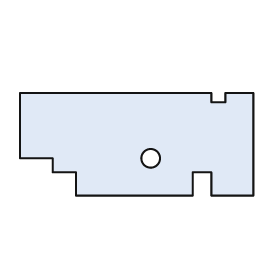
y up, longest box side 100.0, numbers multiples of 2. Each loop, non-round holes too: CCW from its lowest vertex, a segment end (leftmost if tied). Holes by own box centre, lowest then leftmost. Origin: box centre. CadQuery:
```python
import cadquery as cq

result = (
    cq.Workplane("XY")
    .moveTo(-26.0, -22.0)
    .lineTo(24.0, -22.0)
    .lineTo(24.0, -12.0)
    .lineTo(32.0, -12.0)
    .lineTo(32.0, -22.0)
    .lineTo(50.0, -22.0)
    .lineTo(50.0, 22.0)
    .lineTo(38.0, 22.0)
    .lineTo(38.0, 18.0)
    .lineTo(32.0, 18.0)
    .lineTo(32.0, 22.0)
    .lineTo(-50.0, 22.0)
    .lineTo(-50.0, -6.0)
    .lineTo(-36.0, -6.0)
    .lineTo(-36.0, -12.0)
    .lineTo(-26.0, -12.0)
    .close()
    .moveTo(6.0, -6.0)
    .circle(4.0)
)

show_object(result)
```